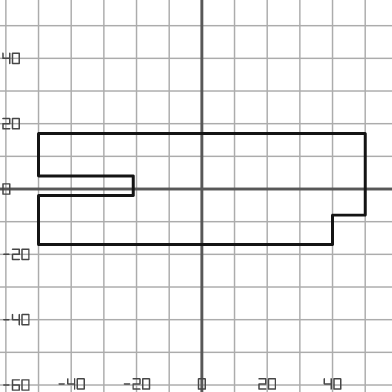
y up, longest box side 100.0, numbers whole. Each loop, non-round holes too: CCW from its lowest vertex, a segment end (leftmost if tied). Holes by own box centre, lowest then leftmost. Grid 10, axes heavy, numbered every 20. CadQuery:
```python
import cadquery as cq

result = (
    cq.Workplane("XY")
    .moveTo(-50.0, -17.0)
    .lineTo(40.0, -17.0)
    .lineTo(40.0, -8.0)
    .lineTo(50.0, -8.0)
    .lineTo(50.0, 17.0)
    .lineTo(-50.0, 17.0)
    .lineTo(-50.0, 4.0)
    .lineTo(-21.0, 4.0)
    .lineTo(-21.0, -2.0)
    .lineTo(-50.0, -2.0)
    .close()
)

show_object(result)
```